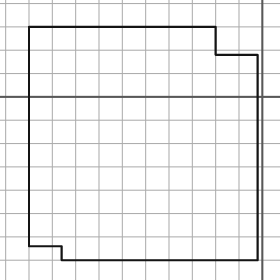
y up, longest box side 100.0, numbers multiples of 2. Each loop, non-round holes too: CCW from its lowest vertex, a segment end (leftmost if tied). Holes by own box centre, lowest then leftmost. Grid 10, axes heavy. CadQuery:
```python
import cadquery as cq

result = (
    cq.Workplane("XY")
    .moveTo(-86.0, -70.0)
    .lineTo(-2.0, -70.0)
    .lineTo(-2.0, 18.0)
    .lineTo(-20.0, 18.0)
    .lineTo(-20.0, 30.0)
    .lineTo(-100.0, 30.0)
    .lineTo(-100.0, -64.0)
    .lineTo(-86.0, -64.0)
    .close()
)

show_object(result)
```